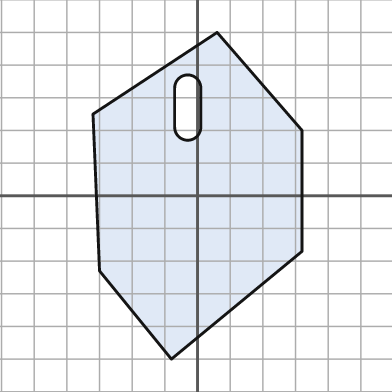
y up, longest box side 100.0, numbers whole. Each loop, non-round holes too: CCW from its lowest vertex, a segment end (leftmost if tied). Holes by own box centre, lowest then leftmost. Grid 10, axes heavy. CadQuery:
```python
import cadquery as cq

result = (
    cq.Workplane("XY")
    .moveTo(-8.0, -50.0)
    .lineTo(32.0, -17.0)
    .lineTo(32.0, 20.0)
    .lineTo(6.0, 50.0)
    .lineTo(-32.0, 25.0)
    .lineTo(-30.0, -23.0)
    .close()
    .moveTo(-7.0, 21.0)
    .threePointArc((-3.0, 17.0), (1.0, 21.0))
    .lineTo(1.0, 33.0)
    .threePointArc((-3.0, 37.0), (-7.0, 33.0))
    .close()
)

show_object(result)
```